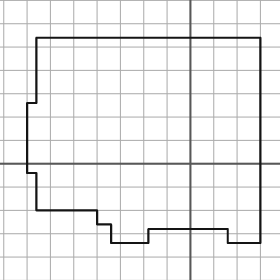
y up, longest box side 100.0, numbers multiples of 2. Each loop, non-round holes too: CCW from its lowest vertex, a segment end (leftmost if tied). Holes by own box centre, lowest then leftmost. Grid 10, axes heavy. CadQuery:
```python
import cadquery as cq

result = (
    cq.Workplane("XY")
    .moveTo(-34.0, -34.0)
    .lineTo(-18.0, -34.0)
    .lineTo(-18.0, -28.0)
    .lineTo(16.0, -28.0)
    .lineTo(16.0, -34.0)
    .lineTo(30.0, -34.0)
    .lineTo(30.0, 54.0)
    .lineTo(-66.0, 54.0)
    .lineTo(-66.0, 26.0)
    .lineTo(-70.0, 26.0)
    .lineTo(-70.0, -4.0)
    .lineTo(-66.0, -4.0)
    .lineTo(-66.0, -20.0)
    .lineTo(-40.0, -20.0)
    .lineTo(-40.0, -26.0)
    .lineTo(-34.0, -26.0)
    .close()
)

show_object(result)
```